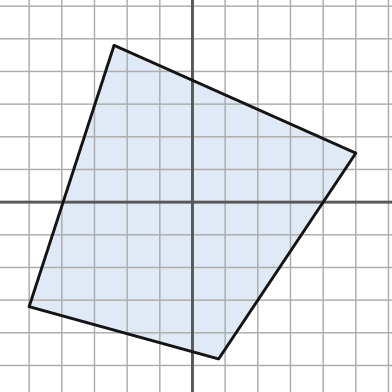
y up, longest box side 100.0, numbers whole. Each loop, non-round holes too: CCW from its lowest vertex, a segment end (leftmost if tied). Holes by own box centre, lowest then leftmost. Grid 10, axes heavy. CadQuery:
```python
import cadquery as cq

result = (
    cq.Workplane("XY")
    .moveTo(8.0, -48.0)
    .lineTo(50.0, 15.0)
    .lineTo(-24.0, 48.0)
    .lineTo(-50.0, -32.0)
    .close()
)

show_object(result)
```